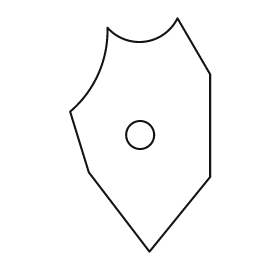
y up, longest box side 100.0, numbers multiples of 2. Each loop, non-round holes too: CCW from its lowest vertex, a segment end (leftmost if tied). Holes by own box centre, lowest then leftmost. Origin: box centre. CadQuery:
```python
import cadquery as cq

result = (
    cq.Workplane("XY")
    .moveTo(4.0, -50.0)
    .lineTo(30.0, -18.0)
    .lineTo(30.0, 26.0)
    .lineTo(16.0, 50.0)
    .threePointArc((2.0, 40.0), (-14.0, 46.0))
    .threePointArc((-18.0, 26.0), (-30.0, 10.0))
    .lineTo(-22.0, -16.0)
    .close()
    .moveTo(0.0, 0.0)
    .circle(6.0)
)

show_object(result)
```